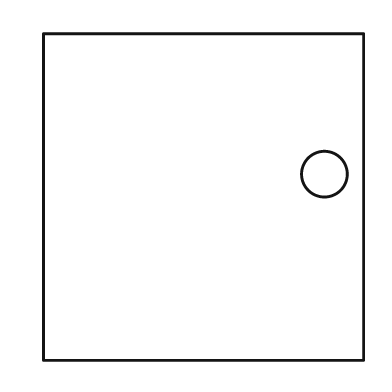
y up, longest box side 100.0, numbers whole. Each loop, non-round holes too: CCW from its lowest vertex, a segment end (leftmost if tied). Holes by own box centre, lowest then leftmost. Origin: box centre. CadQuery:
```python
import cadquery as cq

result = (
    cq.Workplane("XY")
    .moveTo(-49.0, -50.0)
    .lineTo(49.0, -50.0)
    .lineTo(49.0, 50.0)
    .lineTo(-49.0, 50.0)
    .close()
    .moveTo(37.0, 7.0)
    .circle(7.0)
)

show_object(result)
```